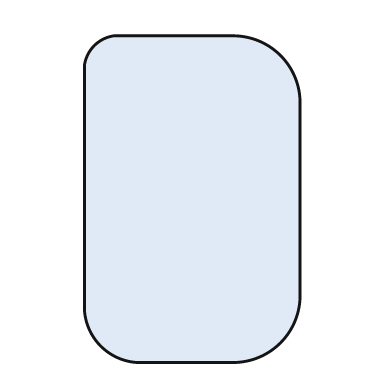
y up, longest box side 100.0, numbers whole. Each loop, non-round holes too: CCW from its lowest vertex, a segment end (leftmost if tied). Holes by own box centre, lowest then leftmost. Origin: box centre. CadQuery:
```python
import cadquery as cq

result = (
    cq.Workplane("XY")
    .moveTo(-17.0, -50.0)
    .lineTo(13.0, -50.0)
    .threePointArc((27.0, -44.0), (33.0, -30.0))
    .lineTo(33.0, 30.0)
    .threePointArc((27.0, 44.0), (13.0, 50.0))
    .lineTo(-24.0, 50.0)
    .threePointArc((-30.0, 47.0), (-33.0, 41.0))
    .lineTo(-33.0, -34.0)
    .threePointArc((-28.0, -45.0), (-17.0, -50.0))
    .close()
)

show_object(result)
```